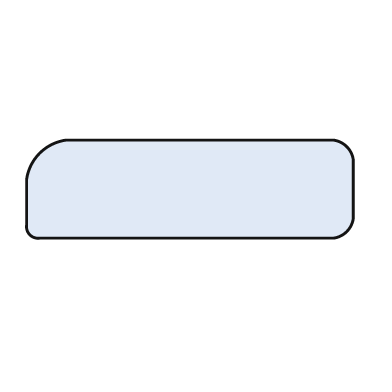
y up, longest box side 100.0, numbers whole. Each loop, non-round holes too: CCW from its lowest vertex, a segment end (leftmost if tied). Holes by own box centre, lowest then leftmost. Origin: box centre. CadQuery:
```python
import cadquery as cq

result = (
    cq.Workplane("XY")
    .moveTo(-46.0, -15.0)
    .lineTo(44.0, -15.0)
    .threePointArc((48.0, -13.0), (50.0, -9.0))
    .lineTo(50.0, 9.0)
    .threePointArc((48.0, 13.0), (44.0, 15.0))
    .lineTo(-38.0, 15.0)
    .threePointArc((-46.0, 11.0), (-50.0, 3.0))
    .lineTo(-50.0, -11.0)
    .threePointArc((-49.0, -14.0), (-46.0, -15.0))
    .close()
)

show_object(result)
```